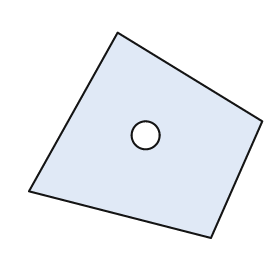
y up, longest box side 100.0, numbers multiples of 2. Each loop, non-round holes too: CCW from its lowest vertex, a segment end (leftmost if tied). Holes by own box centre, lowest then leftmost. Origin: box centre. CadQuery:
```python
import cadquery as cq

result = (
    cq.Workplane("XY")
    .moveTo(28.0, -44.0)
    .lineTo(50.0, 6.0)
    .lineTo(-12.0, 44.0)
    .lineTo(-50.0, -24.0)
    .close()
    .moveTo(0.0, 0.0)
    .circle(6.0)
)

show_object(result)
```